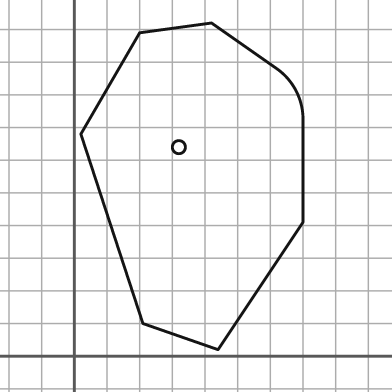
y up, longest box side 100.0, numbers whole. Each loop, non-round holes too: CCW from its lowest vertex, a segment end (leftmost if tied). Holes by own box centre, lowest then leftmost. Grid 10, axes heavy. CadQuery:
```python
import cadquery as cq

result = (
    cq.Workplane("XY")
    .moveTo(44.0, 2.0)
    .lineTo(70.0, 41.0)
    .lineTo(70.0, 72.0)
    .threePointArc((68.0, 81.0), (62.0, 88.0))
    .lineTo(42.0, 102.0)
    .lineTo(20.0, 99.0)
    .lineTo(2.0, 68.0)
    .lineTo(21.0, 10.0)
    .close()
    .moveTo(32.0, 64.0)
    .circle(2.0)
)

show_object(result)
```